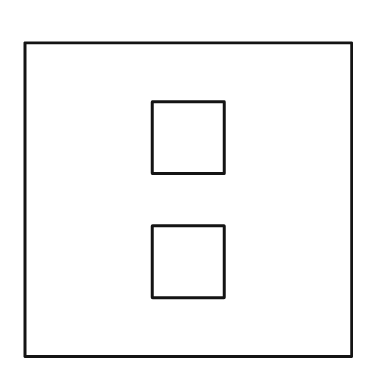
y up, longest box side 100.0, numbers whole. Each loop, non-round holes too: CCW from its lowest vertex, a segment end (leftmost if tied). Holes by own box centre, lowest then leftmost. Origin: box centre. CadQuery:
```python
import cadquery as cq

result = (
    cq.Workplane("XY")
    .moveTo(-50.0, -48.0)
    .lineTo(50.0, -48.0)
    .lineTo(50.0, 48.0)
    .lineTo(-50.0, 48.0)
    .close()
    .moveTo(-11.0, -30.0)
    .lineTo(11.0, -30.0)
    .lineTo(11.0, -8.0)
    .lineTo(-11.0, -8.0)
    .close()
    .moveTo(-11.0, 8.0)
    .lineTo(11.0, 8.0)
    .lineTo(11.0, 30.0)
    .lineTo(-11.0, 30.0)
    .close()
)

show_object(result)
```